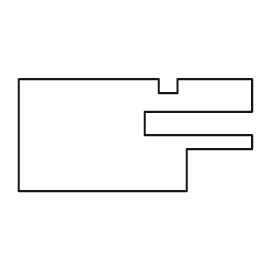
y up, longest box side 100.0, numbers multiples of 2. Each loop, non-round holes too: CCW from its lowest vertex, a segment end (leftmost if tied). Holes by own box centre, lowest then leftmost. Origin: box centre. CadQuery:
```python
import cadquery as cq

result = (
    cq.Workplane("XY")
    .moveTo(-50.0, -24.0)
    .lineTo(22.0, -24.0)
    .lineTo(22.0, -6.0)
    .lineTo(50.0, -6.0)
    .lineTo(50.0, 0.0)
    .lineTo(4.0, 0.0)
    .lineTo(4.0, 10.0)
    .lineTo(50.0, 10.0)
    .lineTo(50.0, 24.0)
    .lineTo(18.0, 24.0)
    .lineTo(18.0, 18.0)
    .lineTo(10.0, 18.0)
    .lineTo(10.0, 24.0)
    .lineTo(-50.0, 24.0)
    .close()
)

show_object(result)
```